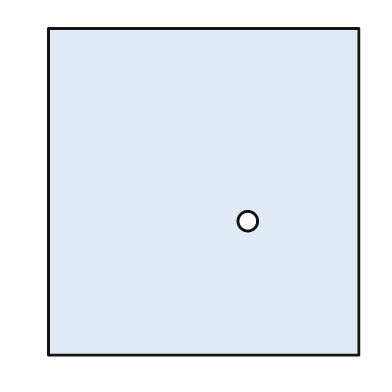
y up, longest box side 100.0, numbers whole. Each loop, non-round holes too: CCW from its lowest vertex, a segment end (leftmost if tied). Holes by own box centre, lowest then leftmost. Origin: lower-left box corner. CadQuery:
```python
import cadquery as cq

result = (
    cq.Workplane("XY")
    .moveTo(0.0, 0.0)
    .lineTo(95.0, 0.0)
    .lineTo(95.0, 100.0)
    .lineTo(0.0, 100.0)
    .close()
    .moveTo(61.0, 41.0)
    .circle(3.0)
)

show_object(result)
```